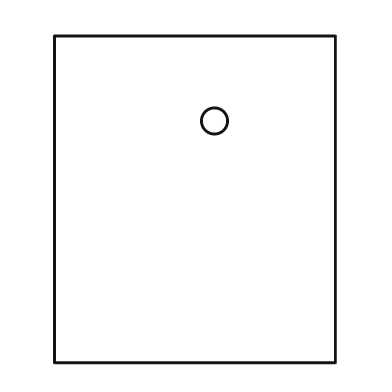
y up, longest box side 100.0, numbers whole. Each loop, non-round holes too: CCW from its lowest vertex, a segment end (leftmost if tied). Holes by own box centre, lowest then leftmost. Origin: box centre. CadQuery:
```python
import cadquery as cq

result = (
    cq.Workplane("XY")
    .moveTo(-43.0, -50.0)
    .lineTo(43.0, -50.0)
    .lineTo(43.0, 50.0)
    .lineTo(-43.0, 50.0)
    .close()
    .moveTo(6.0, 24.0)
    .circle(4.0)
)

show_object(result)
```